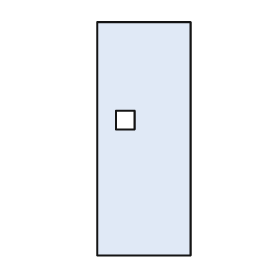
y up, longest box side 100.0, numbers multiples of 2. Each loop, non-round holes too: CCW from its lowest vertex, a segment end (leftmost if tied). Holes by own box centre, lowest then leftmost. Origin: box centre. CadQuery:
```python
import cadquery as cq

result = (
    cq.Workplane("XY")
    .moveTo(-20.0, -50.0)
    .lineTo(20.0, -50.0)
    .lineTo(20.0, 50.0)
    .lineTo(-20.0, 50.0)
    .close()
    .moveTo(-12.0, 4.0)
    .lineTo(-4.0, 4.0)
    .lineTo(-4.0, 12.0)
    .lineTo(-12.0, 12.0)
    .close()
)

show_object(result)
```